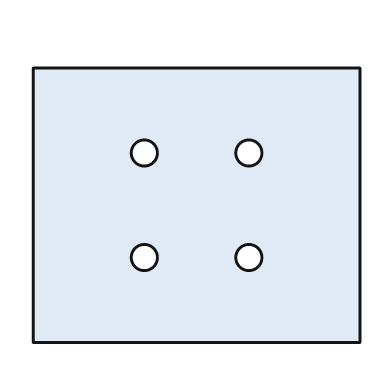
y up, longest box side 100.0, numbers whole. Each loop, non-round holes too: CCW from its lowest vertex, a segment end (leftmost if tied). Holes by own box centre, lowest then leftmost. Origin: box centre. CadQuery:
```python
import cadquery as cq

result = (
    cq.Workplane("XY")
    .moveTo(-50.0, -42.0)
    .lineTo(50.0, -42.0)
    .lineTo(50.0, 42.0)
    .lineTo(-50.0, 42.0)
    .close()
    .moveTo(-16.0, -16.0)
    .circle(4.0)
    .moveTo(16.0, -16.0)
    .circle(4.0)
    .moveTo(-16.0, 16.0)
    .circle(4.0)
    .moveTo(16.0, 16.0)
    .circle(4.0)
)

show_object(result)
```